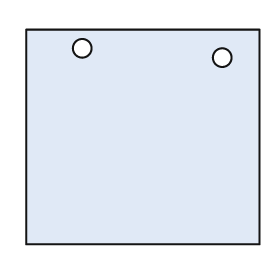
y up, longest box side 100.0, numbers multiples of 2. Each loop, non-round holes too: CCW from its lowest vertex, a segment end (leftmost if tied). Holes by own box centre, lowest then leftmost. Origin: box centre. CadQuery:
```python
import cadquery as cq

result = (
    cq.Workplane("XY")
    .moveTo(-50.0, -46.0)
    .lineTo(50.0, -46.0)
    .lineTo(50.0, 46.0)
    .lineTo(-50.0, 46.0)
    .close()
    .moveTo(34.0, 34.0)
    .circle(4.0)
    .moveTo(-26.0, 38.0)
    .circle(4.0)
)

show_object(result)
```